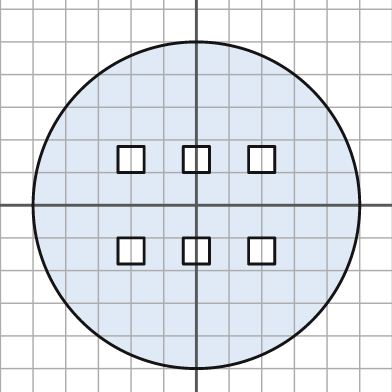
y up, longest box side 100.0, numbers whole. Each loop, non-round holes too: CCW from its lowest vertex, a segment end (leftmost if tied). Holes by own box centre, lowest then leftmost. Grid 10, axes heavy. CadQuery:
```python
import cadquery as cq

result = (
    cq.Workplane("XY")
    .moveTo(0.0, 0.0)
    .circle(50.0)
    .moveTo(-24.0, -18.0)
    .lineTo(-16.0, -18.0)
    .lineTo(-16.0, -10.0)
    .lineTo(-24.0, -10.0)
    .close()
    .moveTo(-4.0, -18.0)
    .lineTo(4.0, -18.0)
    .lineTo(4.0, -10.0)
    .lineTo(-4.0, -10.0)
    .close()
    .moveTo(16.0, -18.0)
    .lineTo(24.0, -18.0)
    .lineTo(24.0, -10.0)
    .lineTo(16.0, -10.0)
    .close()
    .moveTo(-24.0, 10.0)
    .lineTo(-16.0, 10.0)
    .lineTo(-16.0, 18.0)
    .lineTo(-24.0, 18.0)
    .close()
    .moveTo(-4.0, 10.0)
    .lineTo(4.0, 10.0)
    .lineTo(4.0, 18.0)
    .lineTo(-4.0, 18.0)
    .close()
    .moveTo(16.0, 10.0)
    .lineTo(24.0, 10.0)
    .lineTo(24.0, 18.0)
    .lineTo(16.0, 18.0)
    .close()
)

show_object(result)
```